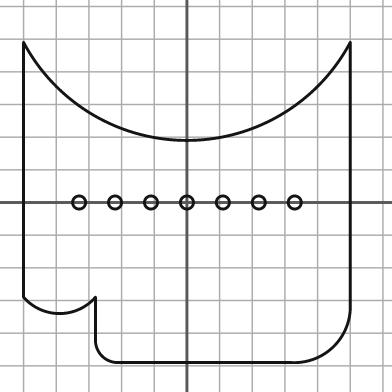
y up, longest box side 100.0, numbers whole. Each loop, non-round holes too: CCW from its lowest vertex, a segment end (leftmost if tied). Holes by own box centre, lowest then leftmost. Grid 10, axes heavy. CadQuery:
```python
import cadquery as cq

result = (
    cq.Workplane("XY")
    .moveTo(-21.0, -49.0)
    .lineTo(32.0, -49.0)
    .threePointArc((45.0, -44.0), (50.0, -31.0))
    .lineTo(50.0, 49.0)
    .threePointArc((0.0, 19.0), (-50.0, 49.0))
    .lineTo(-50.0, -29.0)
    .threePointArc((-39.0, -34.0), (-28.0, -29.0))
    .lineTo(-28.0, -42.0)
    .threePointArc((-26.0, -47.0), (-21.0, -49.0))
    .close()
    .moveTo(-33.0, 0.0)
    .circle(2.0)
    .moveTo(-22.0, 0.0)
    .circle(2.0)
    .moveTo(-11.0, 0.0)
    .circle(2.0)
    .moveTo(0.0, 0.0)
    .circle(2.0)
    .moveTo(11.0, 0.0)
    .circle(2.0)
    .moveTo(22.0, 0.0)
    .circle(2.0)
    .moveTo(33.0, 0.0)
    .circle(2.0)
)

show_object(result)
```